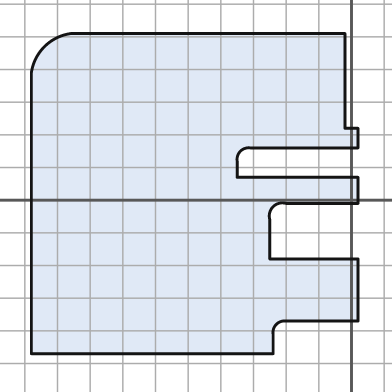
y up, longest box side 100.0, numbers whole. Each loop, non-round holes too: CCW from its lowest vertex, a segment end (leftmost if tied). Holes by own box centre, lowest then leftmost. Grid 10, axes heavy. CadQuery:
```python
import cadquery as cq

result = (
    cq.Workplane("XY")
    .moveTo(-98.0, -47.0)
    .lineTo(-24.0, -47.0)
    .lineTo(-24.0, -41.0)
    .threePointArc((-23.0, -38.0), (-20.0, -37.0))
    .lineTo(2.0, -37.0)
    .lineTo(2.0, -18.0)
    .lineTo(-25.0, -18.0)
    .lineTo(-25.0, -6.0)
    .threePointArc((-24.0, -2.0), (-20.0, -1.0))
    .lineTo(2.0, -1.0)
    .lineTo(2.0, 7.0)
    .lineTo(-35.0, 7.0)
    .lineTo(-35.0, 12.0)
    .threePointArc((-34.0, 15.0), (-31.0, 16.0))
    .lineTo(2.0, 16.0)
    .lineTo(2.0, 22.0)
    .lineTo(-2.0, 22.0)
    .lineTo(-2.0, 51.0)
    .lineTo(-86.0, 51.0)
    .threePointArc((-94.0, 47.0), (-98.0, 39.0))
    .close()
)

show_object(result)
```